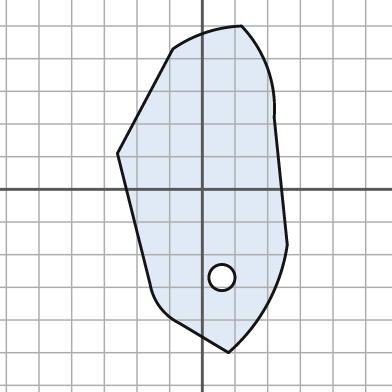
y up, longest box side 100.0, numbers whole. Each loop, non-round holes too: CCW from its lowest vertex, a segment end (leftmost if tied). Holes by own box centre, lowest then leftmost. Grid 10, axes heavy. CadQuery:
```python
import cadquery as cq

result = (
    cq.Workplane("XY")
    .moveTo(8.0, -50.0)
    .threePointArc((20.0, -35.0), (26.0, -17.0))
    .lineTo(22.0, 22.0)
    .threePointArc((20.0, 37.0), (12.0, 50.0))
    .threePointArc((1.0, 48.0), (-9.0, 43.0))
    .lineTo(-26.0, 11.0)
    .lineTo(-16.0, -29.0)
    .threePointArc((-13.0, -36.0), (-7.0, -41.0))
    .close()
    .moveTo(6.0, -27.0)
    .circle(4.0)
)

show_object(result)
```